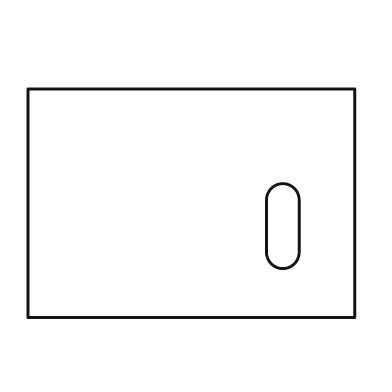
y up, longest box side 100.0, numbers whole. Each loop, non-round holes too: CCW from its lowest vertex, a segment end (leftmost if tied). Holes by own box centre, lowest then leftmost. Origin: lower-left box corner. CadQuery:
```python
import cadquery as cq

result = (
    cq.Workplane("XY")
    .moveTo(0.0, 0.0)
    .lineTo(100.0, 0.0)
    .lineTo(100.0, 70.0)
    .lineTo(0.0, 70.0)
    .close()
    .moveTo(73.0, 20.0)
    .threePointArc((78.0, 15.0), (83.0, 20.0))
    .lineTo(83.0, 36.0)
    .threePointArc((78.0, 41.0), (73.0, 36.0))
    .close()
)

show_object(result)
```